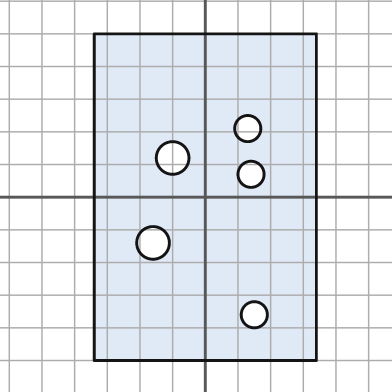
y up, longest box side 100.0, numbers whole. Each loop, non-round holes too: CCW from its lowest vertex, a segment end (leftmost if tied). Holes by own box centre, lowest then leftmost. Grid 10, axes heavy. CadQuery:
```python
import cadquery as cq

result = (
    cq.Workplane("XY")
    .moveTo(-34.0, -50.0)
    .lineTo(34.0, -50.0)
    .lineTo(34.0, 50.0)
    .lineTo(-34.0, 50.0)
    .close()
    .moveTo(15.0, -36.0)
    .circle(4.0)
    .moveTo(-16.0, -14.0)
    .circle(5.0)
    .moveTo(14.0, 7.0)
    .circle(4.0)
    .moveTo(-10.0, 12.0)
    .circle(5.0)
    .moveTo(13.0, 21.0)
    .circle(4.0)
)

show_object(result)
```